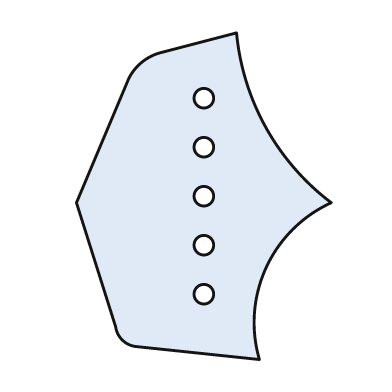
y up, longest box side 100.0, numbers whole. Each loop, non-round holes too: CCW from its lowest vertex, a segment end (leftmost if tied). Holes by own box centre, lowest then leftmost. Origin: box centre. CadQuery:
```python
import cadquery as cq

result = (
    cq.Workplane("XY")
    .moveTo(17.0, -50.0)
    .threePointArc((19.0, -22.0), (39.0, -2.0))
    .threePointArc((19.0, 21.0), (10.0, 50.0))
    .lineTo(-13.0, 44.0)
    .threePointArc((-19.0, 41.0), (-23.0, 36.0))
    .lineTo(-39.0, -2.0)
    .lineTo(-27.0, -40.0)
    .threePointArc((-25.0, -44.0), (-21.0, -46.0))
    .close()
    .moveTo(0.0, -30.0)
    .circle(3.0)
    .moveTo(0.0, -15.0)
    .circle(3.0)
    .moveTo(0.0, 0.0)
    .circle(3.0)
    .moveTo(0.0, 15.0)
    .circle(3.0)
    .moveTo(0.0, 30.0)
    .circle(3.0)
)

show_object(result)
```